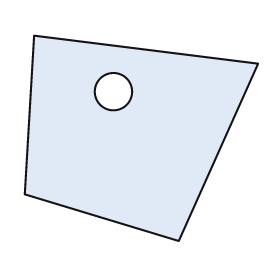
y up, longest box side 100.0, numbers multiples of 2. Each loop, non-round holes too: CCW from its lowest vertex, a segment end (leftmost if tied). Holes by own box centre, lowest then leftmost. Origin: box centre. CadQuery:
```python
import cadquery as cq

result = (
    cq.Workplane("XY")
    .moveTo(16.0, -44.0)
    .lineTo(50.0, 32.0)
    .lineTo(-46.0, 44.0)
    .lineTo(-50.0, -24.0)
    .close()
    .moveTo(-12.0, 20.0)
    .circle(8.0)
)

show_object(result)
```